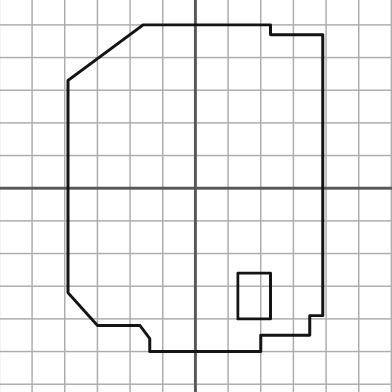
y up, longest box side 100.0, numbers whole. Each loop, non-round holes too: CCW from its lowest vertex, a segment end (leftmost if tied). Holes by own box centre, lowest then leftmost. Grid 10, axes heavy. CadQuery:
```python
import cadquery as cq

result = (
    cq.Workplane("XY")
    .moveTo(-14.0, -50.0)
    .lineTo(20.0, -50.0)
    .lineTo(20.0, -45.0)
    .lineTo(35.0, -45.0)
    .lineTo(35.0, -39.0)
    .lineTo(39.0, -39.0)
    .lineTo(39.0, 47.0)
    .lineTo(23.0, 47.0)
    .lineTo(23.0, 50.0)
    .lineTo(-16.0, 50.0)
    .lineTo(-39.0, 33.0)
    .lineTo(-39.0, -32.0)
    .lineTo(-30.0, -42.0)
    .lineTo(-17.0, -42.0)
    .lineTo(-14.0, -46.0)
    .close()
    .moveTo(13.0, -40.0)
    .lineTo(23.0, -40.0)
    .lineTo(23.0, -26.0)
    .lineTo(13.0, -26.0)
    .close()
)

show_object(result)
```